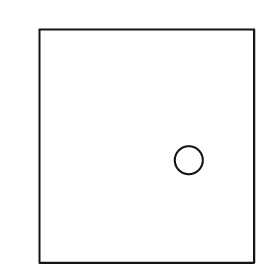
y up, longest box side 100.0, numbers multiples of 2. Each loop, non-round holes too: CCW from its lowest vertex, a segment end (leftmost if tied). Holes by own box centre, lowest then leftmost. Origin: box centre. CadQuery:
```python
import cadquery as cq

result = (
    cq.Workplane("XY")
    .moveTo(-46.0, -50.0)
    .lineTo(46.0, -50.0)
    .lineTo(46.0, 50.0)
    .lineTo(-46.0, 50.0)
    .close()
    .moveTo(18.0, -6.0)
    .circle(6.0)
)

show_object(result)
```